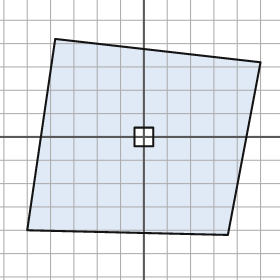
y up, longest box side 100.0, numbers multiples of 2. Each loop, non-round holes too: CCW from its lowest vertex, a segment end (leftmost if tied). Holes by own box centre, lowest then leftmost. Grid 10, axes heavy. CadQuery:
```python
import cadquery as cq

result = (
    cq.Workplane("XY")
    .moveTo(36.0, -42.0)
    .lineTo(50.0, 32.0)
    .lineTo(-38.0, 42.0)
    .lineTo(-50.0, -40.0)
    .close()
    .moveTo(-4.0, -4.0)
    .lineTo(4.0, -4.0)
    .lineTo(4.0, 4.0)
    .lineTo(-4.0, 4.0)
    .close()
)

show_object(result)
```